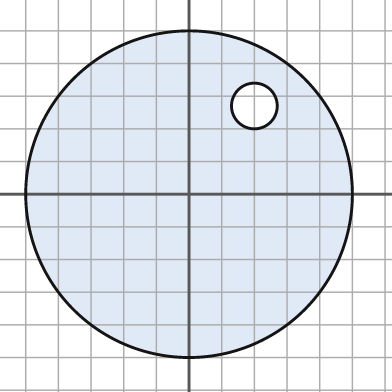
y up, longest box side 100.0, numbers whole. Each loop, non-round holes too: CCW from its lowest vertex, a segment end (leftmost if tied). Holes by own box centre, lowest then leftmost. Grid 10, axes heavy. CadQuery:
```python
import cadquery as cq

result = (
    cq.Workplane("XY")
    .moveTo(0.0, 0.0)
    .circle(50.0)
    .moveTo(20.0, 27.0)
    .circle(7.0)
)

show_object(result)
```